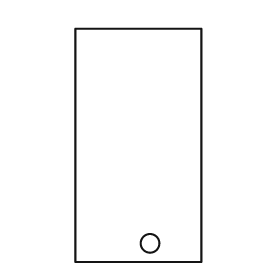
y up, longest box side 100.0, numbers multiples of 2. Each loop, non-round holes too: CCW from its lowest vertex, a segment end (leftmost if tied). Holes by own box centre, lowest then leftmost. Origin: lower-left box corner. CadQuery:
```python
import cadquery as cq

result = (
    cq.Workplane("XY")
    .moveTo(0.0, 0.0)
    .lineTo(54.0, 0.0)
    .lineTo(54.0, 100.0)
    .lineTo(0.0, 100.0)
    .close()
    .moveTo(32.0, 8.0)
    .circle(4.0)
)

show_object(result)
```